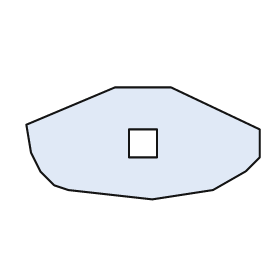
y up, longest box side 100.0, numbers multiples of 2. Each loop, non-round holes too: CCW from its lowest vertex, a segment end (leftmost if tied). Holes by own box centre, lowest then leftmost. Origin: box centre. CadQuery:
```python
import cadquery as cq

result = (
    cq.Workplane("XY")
    .moveTo(4.0, -24.0)
    .lineTo(30.0, -20.0)
    .lineTo(44.0, -12.0)
    .lineTo(50.0, -6.0)
    .lineTo(50.0, 6.0)
    .lineTo(12.0, 24.0)
    .lineTo(-12.0, 24.0)
    .lineTo(-50.0, 8.0)
    .lineTo(-48.0, -4.0)
    .lineTo(-44.0, -12.0)
    .lineTo(-38.0, -18.0)
    .lineTo(-32.0, -20.0)
    .close()
    .moveTo(-6.0, -6.0)
    .lineTo(6.0, -6.0)
    .lineTo(6.0, 6.0)
    .lineTo(-6.0, 6.0)
    .close()
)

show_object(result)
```